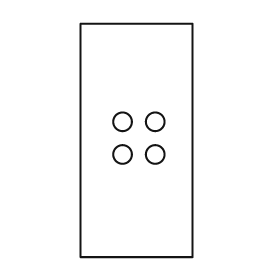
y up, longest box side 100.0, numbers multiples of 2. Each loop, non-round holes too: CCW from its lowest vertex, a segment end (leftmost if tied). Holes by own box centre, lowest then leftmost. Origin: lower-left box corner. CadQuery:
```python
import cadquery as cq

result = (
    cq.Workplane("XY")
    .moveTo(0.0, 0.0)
    .lineTo(48.0, 0.0)
    .lineTo(48.0, 100.0)
    .lineTo(0.0, 100.0)
    .close()
    .moveTo(18.0, 44.0)
    .circle(4.0)
    .moveTo(32.0, 44.0)
    .circle(4.0)
    .moveTo(18.0, 58.0)
    .circle(4.0)
    .moveTo(32.0, 58.0)
    .circle(4.0)
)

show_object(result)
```